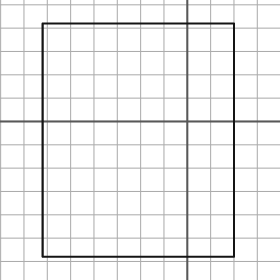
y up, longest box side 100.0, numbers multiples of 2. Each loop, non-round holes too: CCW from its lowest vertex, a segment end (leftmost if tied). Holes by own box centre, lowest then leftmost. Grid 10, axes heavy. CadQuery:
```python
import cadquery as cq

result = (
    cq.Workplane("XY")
    .moveTo(-62.0, -58.0)
    .lineTo(20.0, -58.0)
    .lineTo(20.0, 42.0)
    .lineTo(-62.0, 42.0)
    .close()
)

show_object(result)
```